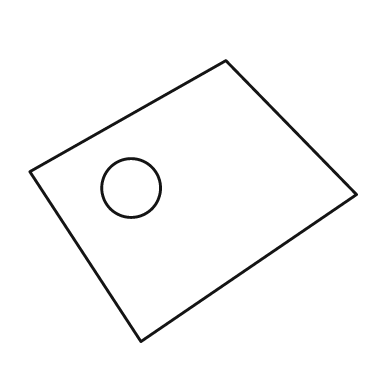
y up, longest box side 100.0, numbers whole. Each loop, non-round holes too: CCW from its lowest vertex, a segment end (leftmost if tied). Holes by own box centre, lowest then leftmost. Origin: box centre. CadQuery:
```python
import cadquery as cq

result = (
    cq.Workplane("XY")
    .moveTo(-16.0, -43.0)
    .lineTo(50.0, 2.0)
    .lineTo(10.0, 43.0)
    .lineTo(-50.0, 9.0)
    .close()
    .moveTo(-19.0, 4.0)
    .circle(9.0)
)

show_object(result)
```